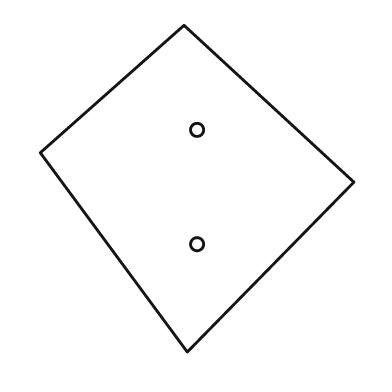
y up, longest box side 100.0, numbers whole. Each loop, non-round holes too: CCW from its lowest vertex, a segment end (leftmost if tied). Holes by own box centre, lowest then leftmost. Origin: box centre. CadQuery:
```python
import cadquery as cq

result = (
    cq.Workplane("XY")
    .moveTo(-3.0, -50.0)
    .lineTo(48.0, 2.0)
    .lineTo(-4.0, 50.0)
    .lineTo(-48.0, 11.0)
    .close()
    .moveTo(0.0, -17.0)
    .circle(2.0)
    .moveTo(0.0, 18.0)
    .circle(2.0)
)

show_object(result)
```